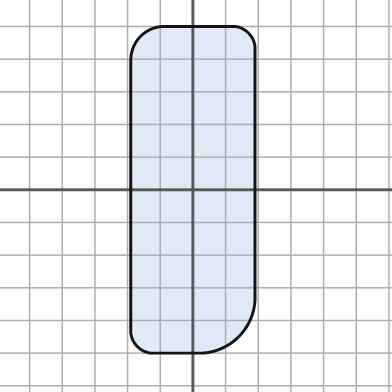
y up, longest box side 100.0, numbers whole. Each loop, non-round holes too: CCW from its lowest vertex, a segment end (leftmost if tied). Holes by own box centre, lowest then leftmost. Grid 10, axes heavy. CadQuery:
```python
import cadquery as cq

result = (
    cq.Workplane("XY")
    .moveTo(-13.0, -50.0)
    .lineTo(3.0, -50.0)
    .threePointArc((14.0, -45.0), (19.0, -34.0))
    .lineTo(19.0, 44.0)
    .threePointArc((17.0, 48.0), (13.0, 50.0))
    .lineTo(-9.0, 50.0)
    .threePointArc((-16.0, 47.0), (-19.0, 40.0))
    .lineTo(-19.0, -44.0)
    .threePointArc((-17.0, -48.0), (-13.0, -50.0))
    .close()
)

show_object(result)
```